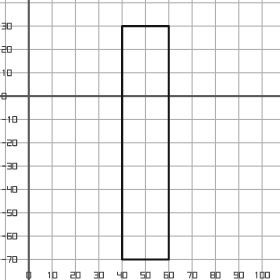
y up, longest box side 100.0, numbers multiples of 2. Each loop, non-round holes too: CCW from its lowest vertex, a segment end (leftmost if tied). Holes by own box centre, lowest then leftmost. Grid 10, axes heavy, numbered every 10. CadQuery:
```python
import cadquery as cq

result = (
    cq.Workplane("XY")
    .moveTo(40.0, -70.0)
    .lineTo(60.0, -70.0)
    .lineTo(60.0, 30.0)
    .lineTo(40.0, 30.0)
    .close()
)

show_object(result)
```